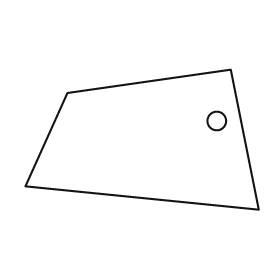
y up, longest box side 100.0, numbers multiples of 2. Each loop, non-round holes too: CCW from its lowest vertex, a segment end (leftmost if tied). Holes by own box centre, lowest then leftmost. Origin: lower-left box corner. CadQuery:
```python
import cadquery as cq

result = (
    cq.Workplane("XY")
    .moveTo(100.0, 0.0)
    .lineTo(88.0, 60.0)
    .lineTo(18.0, 50.0)
    .lineTo(0.0, 10.0)
    .close()
    .moveTo(82.0, 38.0)
    .circle(4.0)
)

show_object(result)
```